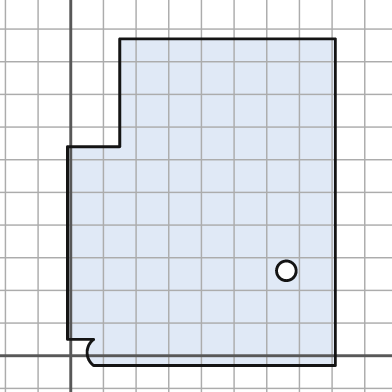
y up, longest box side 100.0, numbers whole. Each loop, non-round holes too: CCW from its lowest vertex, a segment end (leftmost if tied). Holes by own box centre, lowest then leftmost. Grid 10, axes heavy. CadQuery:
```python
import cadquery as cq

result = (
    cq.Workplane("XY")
    .moveTo(7.0, -3.0)
    .lineTo(81.0, -3.0)
    .lineTo(81.0, 97.0)
    .lineTo(15.0, 97.0)
    .lineTo(15.0, 64.0)
    .lineTo(-1.0, 64.0)
    .lineTo(-1.0, 5.0)
    .lineTo(7.0, 5.0)
    .threePointArc((5.0, 1.0), (7.0, -3.0))
    .close()
    .moveTo(66.0, 26.0)
    .circle(3.0)
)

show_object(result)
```